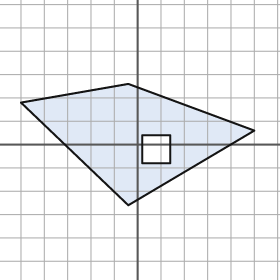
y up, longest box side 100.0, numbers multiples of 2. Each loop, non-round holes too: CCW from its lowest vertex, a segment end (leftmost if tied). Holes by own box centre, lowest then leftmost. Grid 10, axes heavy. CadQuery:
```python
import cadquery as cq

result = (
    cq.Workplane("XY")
    .moveTo(-4.0, -26.0)
    .lineTo(50.0, 6.0)
    .lineTo(-4.0, 26.0)
    .lineTo(-50.0, 18.0)
    .close()
    .moveTo(2.0, -8.0)
    .lineTo(14.0, -8.0)
    .lineTo(14.0, 4.0)
    .lineTo(2.0, 4.0)
    .close()
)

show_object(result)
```